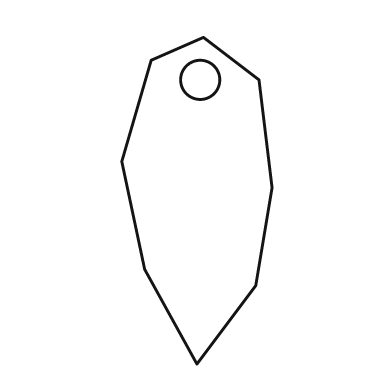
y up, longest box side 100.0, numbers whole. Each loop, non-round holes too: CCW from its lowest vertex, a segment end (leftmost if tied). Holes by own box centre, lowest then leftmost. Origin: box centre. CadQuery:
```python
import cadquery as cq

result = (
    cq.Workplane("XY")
    .moveTo(0.0, -50.0)
    .lineTo(18.0, -26.0)
    .lineTo(23.0, 4.0)
    .lineTo(19.0, 37.0)
    .lineTo(2.0, 50.0)
    .lineTo(-14.0, 43.0)
    .lineTo(-23.0, 12.0)
    .lineTo(-16.0, -21.0)
    .close()
    .moveTo(1.0, 37.0)
    .circle(6.0)
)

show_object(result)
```